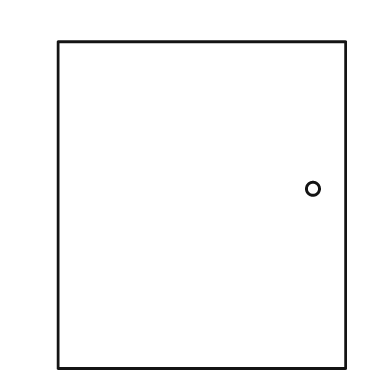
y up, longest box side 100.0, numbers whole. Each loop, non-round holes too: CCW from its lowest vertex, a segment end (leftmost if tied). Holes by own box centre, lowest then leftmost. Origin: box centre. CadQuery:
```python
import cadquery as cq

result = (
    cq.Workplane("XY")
    .moveTo(-44.0, -50.0)
    .lineTo(44.0, -50.0)
    .lineTo(44.0, 50.0)
    .lineTo(-44.0, 50.0)
    .close()
    .moveTo(34.0, 5.0)
    .circle(2.0)
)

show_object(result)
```